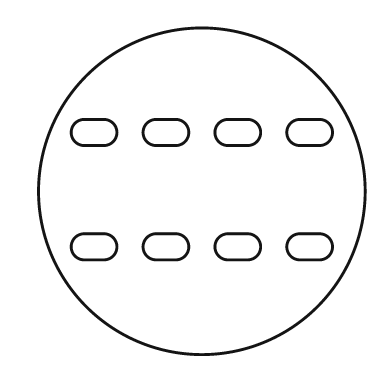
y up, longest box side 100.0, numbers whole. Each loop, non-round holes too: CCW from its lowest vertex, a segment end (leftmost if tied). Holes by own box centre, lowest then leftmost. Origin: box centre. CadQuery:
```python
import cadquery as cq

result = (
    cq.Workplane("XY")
    .moveTo(0.0, 0.0)
    .circle(50.0)
    .moveTo(-36.0, -21.0)
    .lineTo(-30.0, -21.0)
    .threePointArc((-26.0, -17.0), (-30.0, -13.0))
    .lineTo(-36.0, -13.0)
    .threePointArc((-40.0, -17.0), (-36.0, -21.0))
    .close()
    .moveTo(-14.0, -21.0)
    .lineTo(-8.0, -21.0)
    .threePointArc((-4.0, -17.0), (-8.0, -13.0))
    .lineTo(-14.0, -13.0)
    .threePointArc((-18.0, -17.0), (-14.0, -21.0))
    .close()
    .moveTo(8.0, -21.0)
    .lineTo(14.0, -21.0)
    .threePointArc((18.0, -17.0), (14.0, -13.0))
    .lineTo(8.0, -13.0)
    .threePointArc((4.0, -17.0), (8.0, -21.0))
    .close()
    .moveTo(30.0, -21.0)
    .lineTo(36.0, -21.0)
    .threePointArc((40.0, -17.0), (36.0, -13.0))
    .lineTo(30.0, -13.0)
    .threePointArc((26.0, -17.0), (30.0, -21.0))
    .close()
    .moveTo(-36.0, 14.0)
    .lineTo(-30.0, 14.0)
    .threePointArc((-26.0, 18.0), (-30.0, 22.0))
    .lineTo(-36.0, 22.0)
    .threePointArc((-40.0, 18.0), (-36.0, 14.0))
    .close()
    .moveTo(-14.0, 14.0)
    .lineTo(-8.0, 14.0)
    .threePointArc((-4.0, 18.0), (-8.0, 22.0))
    .lineTo(-14.0, 22.0)
    .threePointArc((-18.0, 18.0), (-14.0, 14.0))
    .close()
    .moveTo(8.0, 14.0)
    .lineTo(14.0, 14.0)
    .threePointArc((18.0, 18.0), (14.0, 22.0))
    .lineTo(8.0, 22.0)
    .threePointArc((4.0, 18.0), (8.0, 14.0))
    .close()
    .moveTo(30.0, 14.0)
    .lineTo(36.0, 14.0)
    .threePointArc((40.0, 18.0), (36.0, 22.0))
    .lineTo(30.0, 22.0)
    .threePointArc((26.0, 18.0), (30.0, 14.0))
    .close()
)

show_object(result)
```